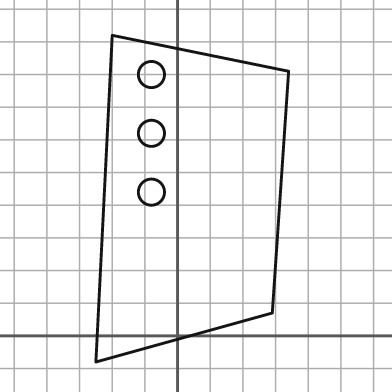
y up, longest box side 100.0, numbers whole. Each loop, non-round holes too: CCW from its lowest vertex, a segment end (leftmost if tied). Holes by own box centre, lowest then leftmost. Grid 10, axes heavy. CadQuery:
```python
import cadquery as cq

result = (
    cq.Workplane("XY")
    .moveTo(-25.0, -8.0)
    .lineTo(29.0, 7.0)
    .lineTo(34.0, 81.0)
    .lineTo(-20.0, 92.0)
    .close()
    .moveTo(-8.0, 44.0)
    .circle(4.0)
    .moveTo(-8.0, 62.0)
    .circle(4.0)
    .moveTo(-8.0, 80.0)
    .circle(4.0)
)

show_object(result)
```